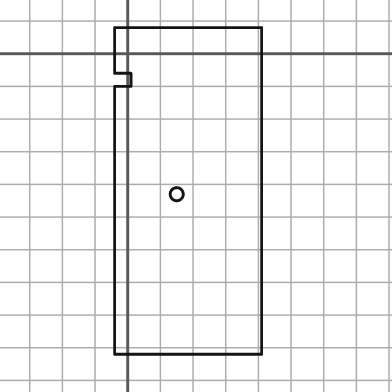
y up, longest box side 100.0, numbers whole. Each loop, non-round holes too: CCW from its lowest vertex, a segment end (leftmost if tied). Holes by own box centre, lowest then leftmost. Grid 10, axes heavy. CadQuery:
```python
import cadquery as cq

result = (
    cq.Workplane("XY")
    .moveTo(-4.0, -92.0)
    .lineTo(41.0, -92.0)
    .lineTo(41.0, 8.0)
    .lineTo(-4.0, 8.0)
    .lineTo(-4.0, -6.0)
    .lineTo(1.0, -6.0)
    .lineTo(1.0, -10.0)
    .lineTo(-4.0, -10.0)
    .close()
    .moveTo(15.0, -43.0)
    .circle(2.0)
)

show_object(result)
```